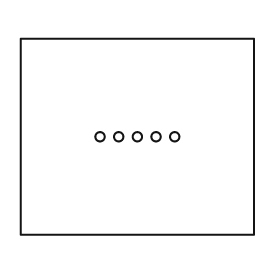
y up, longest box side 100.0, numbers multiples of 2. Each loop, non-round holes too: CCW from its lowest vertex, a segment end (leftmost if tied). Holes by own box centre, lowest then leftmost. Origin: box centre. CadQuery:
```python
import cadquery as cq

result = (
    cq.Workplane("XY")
    .moveTo(-50.0, -42.0)
    .lineTo(50.0, -42.0)
    .lineTo(50.0, 42.0)
    .lineTo(-50.0, 42.0)
    .close()
    .moveTo(-16.0, 0.0)
    .circle(2.0)
    .moveTo(-8.0, 0.0)
    .circle(2.0)
    .moveTo(0.0, 0.0)
    .circle(2.0)
    .moveTo(8.0, 0.0)
    .circle(2.0)
    .moveTo(16.0, 0.0)
    .circle(2.0)
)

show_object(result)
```